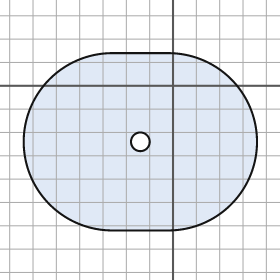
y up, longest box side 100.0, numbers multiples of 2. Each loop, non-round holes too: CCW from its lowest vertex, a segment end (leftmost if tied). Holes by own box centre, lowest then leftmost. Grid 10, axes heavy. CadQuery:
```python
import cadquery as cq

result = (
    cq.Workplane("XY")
    .moveTo(-26.0, -62.0)
    .lineTo(-2.0, -62.0)
    .threePointArc((36.0, -24.0), (-2.0, 14.0))
    .lineTo(-26.0, 14.0)
    .threePointArc((-64.0, -24.0), (-26.0, -62.0))
    .close()
    .moveTo(-14.0, -24.0)
    .circle(4.0)
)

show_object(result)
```